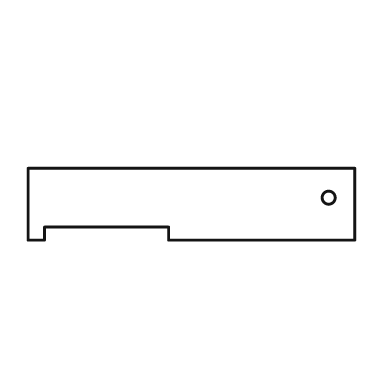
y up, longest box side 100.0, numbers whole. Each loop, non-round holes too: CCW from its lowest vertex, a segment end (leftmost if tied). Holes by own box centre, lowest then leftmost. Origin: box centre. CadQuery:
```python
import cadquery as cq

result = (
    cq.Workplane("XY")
    .moveTo(-50.0, -11.0)
    .lineTo(-45.0, -11.0)
    .lineTo(-45.0, -7.0)
    .lineTo(-7.0, -7.0)
    .lineTo(-7.0, -11.0)
    .lineTo(50.0, -11.0)
    .lineTo(50.0, 11.0)
    .lineTo(-50.0, 11.0)
    .close()
    .moveTo(42.0, 2.0)
    .circle(2.0)
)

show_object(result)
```